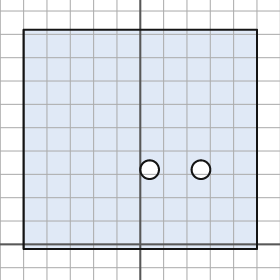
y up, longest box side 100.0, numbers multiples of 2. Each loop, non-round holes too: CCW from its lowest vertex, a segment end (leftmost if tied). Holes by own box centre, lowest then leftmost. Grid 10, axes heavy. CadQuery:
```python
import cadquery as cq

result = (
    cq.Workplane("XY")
    .moveTo(-50.0, -2.0)
    .lineTo(50.0, -2.0)
    .lineTo(50.0, 92.0)
    .lineTo(-50.0, 92.0)
    .close()
    .moveTo(4.0, 32.0)
    .circle(4.0)
    .moveTo(26.0, 32.0)
    .circle(4.0)
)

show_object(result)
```